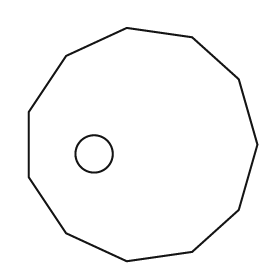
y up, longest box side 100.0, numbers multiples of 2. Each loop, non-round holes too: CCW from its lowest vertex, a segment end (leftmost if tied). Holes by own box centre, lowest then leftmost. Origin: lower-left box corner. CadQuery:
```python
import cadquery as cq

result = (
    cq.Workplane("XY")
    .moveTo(42.0, 0.0)
    .lineTo(70.0, 4.0)
    .lineTo(90.0, 22.0)
    .lineTo(98.0, 50.0)
    .lineTo(90.0, 78.0)
    .lineTo(70.0, 96.0)
    .lineTo(42.0, 100.0)
    .lineTo(16.0, 88.0)
    .lineTo(0.0, 64.0)
    .lineTo(0.0, 36.0)
    .lineTo(16.0, 12.0)
    .close()
    .moveTo(28.0, 46.0)
    .circle(8.0)
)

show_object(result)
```